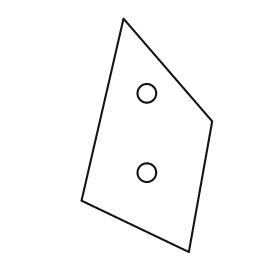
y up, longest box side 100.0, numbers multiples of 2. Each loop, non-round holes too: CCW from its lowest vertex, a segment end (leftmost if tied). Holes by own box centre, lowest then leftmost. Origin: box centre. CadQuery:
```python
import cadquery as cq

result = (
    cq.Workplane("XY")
    .moveTo(18.0, -50.0)
    .lineTo(28.0, 6.0)
    .lineTo(-10.0, 50.0)
    .lineTo(-28.0, -28.0)
    .close()
    .moveTo(0.0, -16.0)
    .circle(4.0)
    .moveTo(0.0, 18.0)
    .circle(4.0)
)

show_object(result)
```